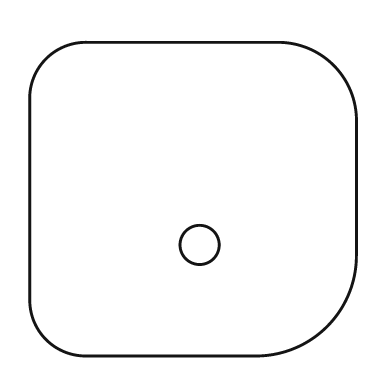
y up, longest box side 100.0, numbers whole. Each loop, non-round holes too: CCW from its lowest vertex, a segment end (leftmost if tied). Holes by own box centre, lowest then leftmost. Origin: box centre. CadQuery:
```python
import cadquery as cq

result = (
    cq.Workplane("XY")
    .moveTo(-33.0, -48.0)
    .lineTo(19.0, -48.0)
    .threePointArc((41.0, -39.0), (50.0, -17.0))
    .lineTo(50.0, 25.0)
    .threePointArc((43.0, 41.0), (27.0, 48.0))
    .lineTo(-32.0, 48.0)
    .threePointArc((-45.0, 43.0), (-50.0, 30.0))
    .lineTo(-50.0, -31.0)
    .threePointArc((-45.0, -43.0), (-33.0, -48.0))
    .close()
    .moveTo(2.0, -14.0)
    .circle(6.0)
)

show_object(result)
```